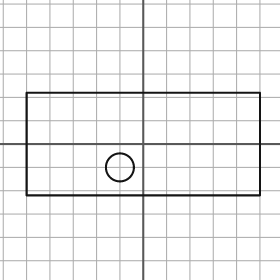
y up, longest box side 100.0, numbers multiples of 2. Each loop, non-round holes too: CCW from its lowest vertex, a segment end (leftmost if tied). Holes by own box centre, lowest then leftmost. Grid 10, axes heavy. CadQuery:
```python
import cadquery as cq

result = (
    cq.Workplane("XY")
    .moveTo(-50.0, -22.0)
    .lineTo(50.0, -22.0)
    .lineTo(50.0, 22.0)
    .lineTo(-50.0, 22.0)
    .close()
    .moveTo(-10.0, -10.0)
    .circle(6.0)
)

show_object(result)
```